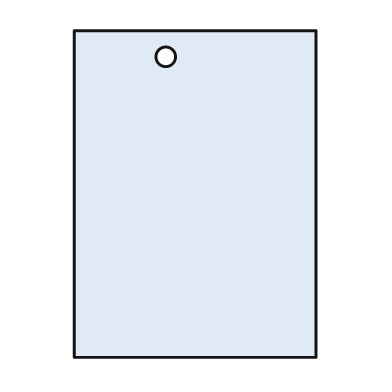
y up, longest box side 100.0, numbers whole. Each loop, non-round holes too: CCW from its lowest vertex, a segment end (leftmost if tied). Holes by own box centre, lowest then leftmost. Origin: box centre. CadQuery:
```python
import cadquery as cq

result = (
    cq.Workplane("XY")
    .moveTo(-37.0, -50.0)
    .lineTo(37.0, -50.0)
    .lineTo(37.0, 50.0)
    .lineTo(-37.0, 50.0)
    .close()
    .moveTo(-9.0, 42.0)
    .circle(3.0)
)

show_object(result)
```